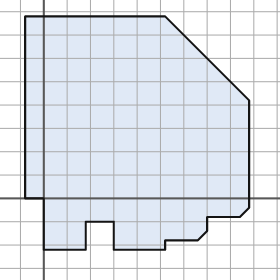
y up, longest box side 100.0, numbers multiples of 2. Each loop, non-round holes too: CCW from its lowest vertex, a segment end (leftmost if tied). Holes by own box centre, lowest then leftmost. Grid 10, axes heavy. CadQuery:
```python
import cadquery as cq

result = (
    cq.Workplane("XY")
    .moveTo(0.0, -22.0)
    .lineTo(18.0, -22.0)
    .lineTo(18.0, -10.0)
    .lineTo(30.0, -10.0)
    .lineTo(30.0, -22.0)
    .lineTo(52.0, -22.0)
    .lineTo(52.0, -18.0)
    .lineTo(66.0, -18.0)
    .lineTo(70.0, -14.0)
    .lineTo(70.0, -8.0)
    .lineTo(84.0, -8.0)
    .lineTo(88.0, -4.0)
    .lineTo(88.0, 42.0)
    .lineTo(52.0, 78.0)
    .lineTo(-8.0, 78.0)
    .lineTo(-8.0, 0.0)
    .lineTo(0.0, 0.0)
    .close()
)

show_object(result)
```